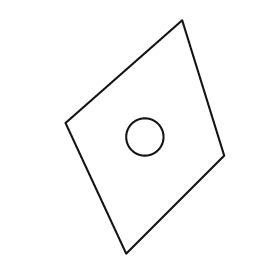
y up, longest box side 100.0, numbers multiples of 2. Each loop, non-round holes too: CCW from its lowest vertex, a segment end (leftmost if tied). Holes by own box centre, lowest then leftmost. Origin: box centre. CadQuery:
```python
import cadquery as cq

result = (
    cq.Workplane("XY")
    .moveTo(-8.0, -50.0)
    .lineTo(34.0, -8.0)
    .lineTo(16.0, 50.0)
    .lineTo(-34.0, 6.0)
    .close()
    .moveTo(0.0, 0.0)
    .circle(8.0)
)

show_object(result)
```